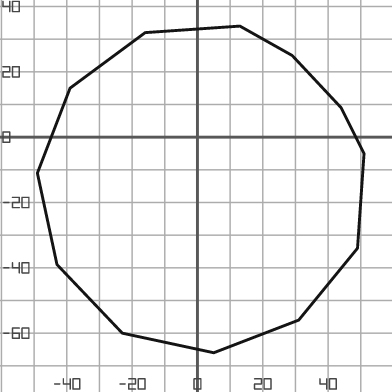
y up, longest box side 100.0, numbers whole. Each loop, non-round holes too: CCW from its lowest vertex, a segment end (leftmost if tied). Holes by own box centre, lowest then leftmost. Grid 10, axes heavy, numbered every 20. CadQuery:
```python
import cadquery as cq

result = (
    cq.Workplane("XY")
    .moveTo(5.0, -66.0)
    .lineTo(31.0, -56.0)
    .lineTo(49.0, -34.0)
    .lineTo(51.0, -5.0)
    .lineTo(44.0, 9.0)
    .lineTo(29.0, 25.0)
    .lineTo(13.0, 34.0)
    .lineTo(-16.0, 32.0)
    .lineTo(-39.0, 15.0)
    .lineTo(-49.0, -11.0)
    .lineTo(-43.0, -39.0)
    .lineTo(-23.0, -60.0)
    .close()
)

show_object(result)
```